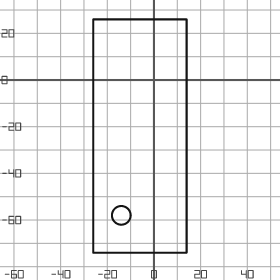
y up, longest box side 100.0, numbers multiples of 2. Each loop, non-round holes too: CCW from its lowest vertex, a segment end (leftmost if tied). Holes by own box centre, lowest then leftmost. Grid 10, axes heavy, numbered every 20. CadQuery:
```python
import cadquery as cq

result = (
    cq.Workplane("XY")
    .moveTo(-26.0, -74.0)
    .lineTo(14.0, -74.0)
    .lineTo(14.0, 26.0)
    .lineTo(-26.0, 26.0)
    .close()
    .moveTo(-14.0, -58.0)
    .circle(4.0)
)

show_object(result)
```